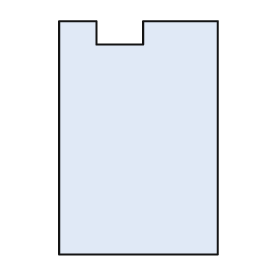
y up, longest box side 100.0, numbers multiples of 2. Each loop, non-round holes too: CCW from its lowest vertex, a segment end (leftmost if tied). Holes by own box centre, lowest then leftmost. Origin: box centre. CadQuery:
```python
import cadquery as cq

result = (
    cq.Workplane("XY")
    .moveTo(-34.0, -50.0)
    .lineTo(34.0, -50.0)
    .lineTo(34.0, 50.0)
    .lineTo(2.0, 50.0)
    .lineTo(2.0, 40.0)
    .lineTo(-18.0, 40.0)
    .lineTo(-18.0, 50.0)
    .lineTo(-34.0, 50.0)
    .close()
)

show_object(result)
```